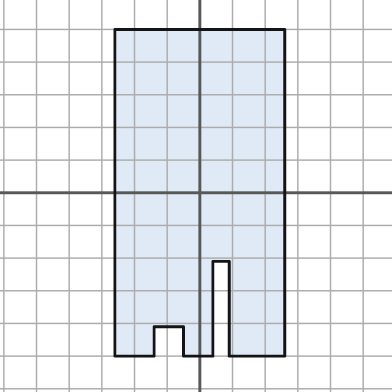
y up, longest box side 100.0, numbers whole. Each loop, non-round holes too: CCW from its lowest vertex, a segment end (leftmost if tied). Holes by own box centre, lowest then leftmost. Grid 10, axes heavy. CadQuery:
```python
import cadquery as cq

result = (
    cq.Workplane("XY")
    .moveTo(-26.0, -50.0)
    .lineTo(-14.0, -50.0)
    .lineTo(-14.0, -41.0)
    .lineTo(-5.0, -41.0)
    .lineTo(-5.0, -50.0)
    .lineTo(4.0, -50.0)
    .lineTo(4.0, -21.0)
    .lineTo(9.0, -21.0)
    .lineTo(9.0, -50.0)
    .lineTo(26.0, -50.0)
    .lineTo(26.0, 50.0)
    .lineTo(-26.0, 50.0)
    .close()
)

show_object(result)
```